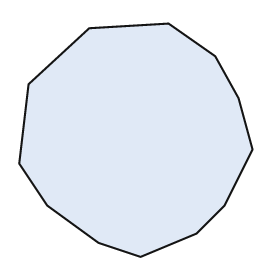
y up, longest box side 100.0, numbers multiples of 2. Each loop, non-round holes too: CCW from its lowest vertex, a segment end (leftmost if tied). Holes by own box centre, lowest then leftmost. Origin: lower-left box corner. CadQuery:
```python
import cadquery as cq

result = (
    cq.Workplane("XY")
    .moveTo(52.0, 0.0)
    .lineTo(76.0, 10.0)
    .lineTo(88.0, 22.0)
    .lineTo(100.0, 46.0)
    .lineTo(94.0, 68.0)
    .lineTo(84.0, 86.0)
    .lineTo(64.0, 100.0)
    .lineTo(30.0, 98.0)
    .lineTo(4.0, 74.0)
    .lineTo(0.0, 40.0)
    .lineTo(12.0, 22.0)
    .lineTo(34.0, 6.0)
    .close()
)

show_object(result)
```